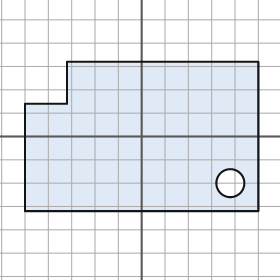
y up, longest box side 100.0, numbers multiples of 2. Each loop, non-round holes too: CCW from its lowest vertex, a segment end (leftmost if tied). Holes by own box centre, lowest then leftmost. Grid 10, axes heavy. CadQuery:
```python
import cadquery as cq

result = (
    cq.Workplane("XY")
    .moveTo(-50.0, -32.0)
    .lineTo(50.0, -32.0)
    .lineTo(50.0, 32.0)
    .lineTo(-32.0, 32.0)
    .lineTo(-32.0, 14.0)
    .lineTo(-50.0, 14.0)
    .close()
    .moveTo(38.0, -20.0)
    .circle(6.0)
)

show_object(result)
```